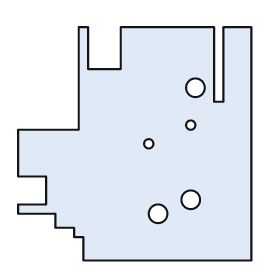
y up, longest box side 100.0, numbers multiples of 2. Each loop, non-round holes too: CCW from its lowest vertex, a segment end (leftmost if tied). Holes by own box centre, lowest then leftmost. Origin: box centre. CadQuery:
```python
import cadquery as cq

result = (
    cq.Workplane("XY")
    .moveTo(-22.0, -50.0)
    .lineTo(50.0, -50.0)
    .lineTo(50.0, 50.0)
    .lineTo(38.0, 50.0)
    .lineTo(38.0, 18.0)
    .lineTo(34.0, 18.0)
    .lineTo(34.0, 50.0)
    .lineTo(-6.0, 50.0)
    .lineTo(-6.0, 32.0)
    .lineTo(-20.0, 32.0)
    .lineTo(-20.0, 50.0)
    .lineTo(-24.0, 50.0)
    .lineTo(-24.0, 6.0)
    .lineTo(-50.0, 6.0)
    .lineTo(-50.0, -14.0)
    .lineTo(-38.0, -14.0)
    .lineTo(-38.0, -26.0)
    .lineTo(-50.0, -26.0)
    .lineTo(-50.0, -30.0)
    .lineTo(-34.0, -30.0)
    .lineTo(-34.0, -36.0)
    .lineTo(-26.0, -36.0)
    .lineTo(-26.0, -40.0)
    .lineTo(-22.0, -40.0)
    .close()
    .moveTo(10.0, -30.0)
    .circle(4.0)
    .moveTo(24.0, -24.0)
    .circle(4.0)
    .moveTo(6.0, 0.0)
    .circle(2.0)
    .moveTo(24.0, 8.0)
    .circle(2.0)
    .moveTo(26.0, 24.0)
    .circle(4.0)
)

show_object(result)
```